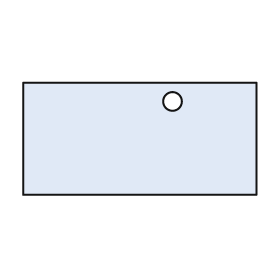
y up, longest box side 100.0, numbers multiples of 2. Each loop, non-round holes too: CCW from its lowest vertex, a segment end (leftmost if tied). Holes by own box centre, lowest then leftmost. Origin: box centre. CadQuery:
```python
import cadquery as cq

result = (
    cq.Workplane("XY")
    .moveTo(-50.0, -24.0)
    .lineTo(50.0, -24.0)
    .lineTo(50.0, 24.0)
    .lineTo(-50.0, 24.0)
    .close()
    .moveTo(14.0, 16.0)
    .circle(4.0)
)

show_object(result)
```